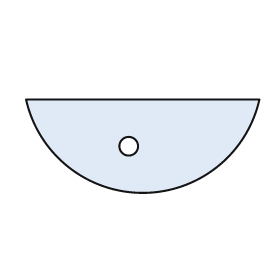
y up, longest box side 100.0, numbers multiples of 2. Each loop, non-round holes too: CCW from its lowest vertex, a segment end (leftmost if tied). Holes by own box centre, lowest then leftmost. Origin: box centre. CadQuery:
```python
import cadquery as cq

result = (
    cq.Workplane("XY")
    .moveTo(-50.0, 20.0)
    .threePointArc((0.0, -20.0), (50.0, 20.0))
    .close()
    .moveTo(-6.0, 0.0)
    .circle(4.0)
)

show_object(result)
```